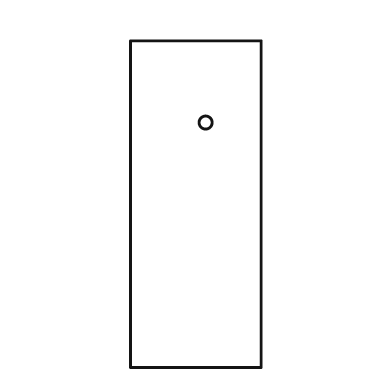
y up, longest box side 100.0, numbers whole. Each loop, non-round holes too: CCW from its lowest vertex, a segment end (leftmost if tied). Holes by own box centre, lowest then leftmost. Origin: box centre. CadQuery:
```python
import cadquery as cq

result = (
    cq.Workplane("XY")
    .moveTo(-20.0, -50.0)
    .lineTo(20.0, -50.0)
    .lineTo(20.0, 50.0)
    .lineTo(-20.0, 50.0)
    .close()
    .moveTo(3.0, 25.0)
    .circle(2.0)
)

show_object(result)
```